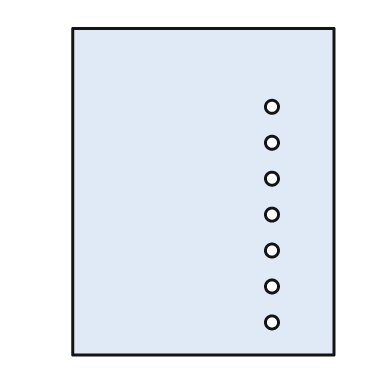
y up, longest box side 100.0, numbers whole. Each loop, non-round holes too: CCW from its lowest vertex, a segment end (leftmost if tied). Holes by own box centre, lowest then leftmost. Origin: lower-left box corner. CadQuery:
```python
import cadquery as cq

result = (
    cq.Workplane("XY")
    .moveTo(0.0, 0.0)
    .lineTo(80.0, 0.0)
    .lineTo(80.0, 100.0)
    .lineTo(0.0, 100.0)
    .close()
    .moveTo(61.0, 10.0)
    .circle(2.0)
    .moveTo(61.0, 21.0)
    .circle(2.0)
    .moveTo(61.0, 32.0)
    .circle(2.0)
    .moveTo(61.0, 43.0)
    .circle(2.0)
    .moveTo(61.0, 54.0)
    .circle(2.0)
    .moveTo(61.0, 65.0)
    .circle(2.0)
    .moveTo(61.0, 76.0)
    .circle(2.0)
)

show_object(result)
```